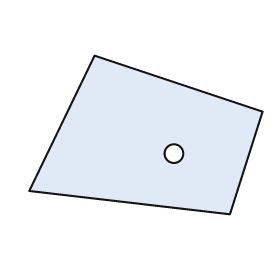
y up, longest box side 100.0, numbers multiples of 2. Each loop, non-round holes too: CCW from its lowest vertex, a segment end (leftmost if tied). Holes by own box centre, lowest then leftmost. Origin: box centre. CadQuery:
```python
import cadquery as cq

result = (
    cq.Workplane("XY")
    .moveTo(36.0, -34.0)
    .lineTo(50.0, 10.0)
    .lineTo(-22.0, 34.0)
    .lineTo(-50.0, -24.0)
    .close()
    .moveTo(12.0, -8.0)
    .circle(4.0)
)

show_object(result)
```